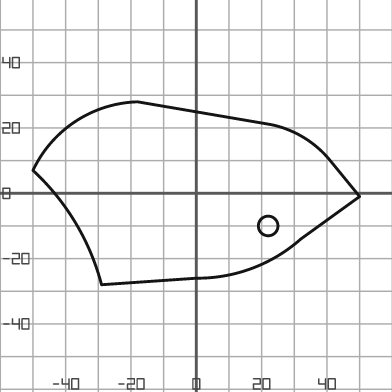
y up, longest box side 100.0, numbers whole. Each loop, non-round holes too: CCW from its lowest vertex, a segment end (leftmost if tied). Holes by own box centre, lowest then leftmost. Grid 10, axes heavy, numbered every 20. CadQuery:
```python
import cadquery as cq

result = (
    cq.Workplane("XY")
    .moveTo(-29.0, -28.0)
    .lineTo(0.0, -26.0)
    .threePointArc((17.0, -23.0), (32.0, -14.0))
    .lineTo(50.0, -1.0)
    .lineTo(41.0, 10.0)
    .threePointArc((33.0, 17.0), (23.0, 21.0))
    .lineTo(-18.0, 28.0)
    .threePointArc((-37.0, 22.0), (-50.0, 7.0))
    .threePointArc((-37.0, -9.0), (-29.0, -28.0))
    .close()
    .moveTo(22.0, -10.0)
    .circle(3.0)
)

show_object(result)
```